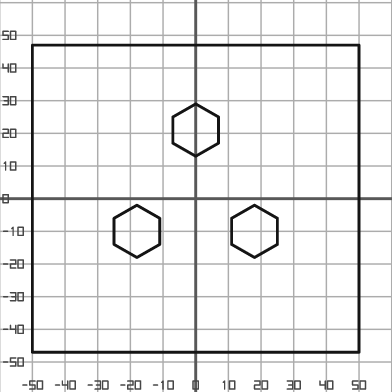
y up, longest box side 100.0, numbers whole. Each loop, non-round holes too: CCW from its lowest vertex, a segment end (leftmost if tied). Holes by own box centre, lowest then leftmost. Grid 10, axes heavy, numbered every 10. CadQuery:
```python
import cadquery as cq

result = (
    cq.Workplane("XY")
    .moveTo(-50.0, -47.0)
    .lineTo(50.0, -47.0)
    .lineTo(50.0, 47.0)
    .lineTo(-50.0, 47.0)
    .close()
    .moveTo(-18.0, -18.0)
    .lineTo(-11.0, -14.0)
    .lineTo(-11.0, -6.0)
    .lineTo(-18.0, -2.0)
    .lineTo(-25.0, -6.0)
    .lineTo(-25.0, -14.0)
    .close()
    .moveTo(18.0, -18.0)
    .lineTo(25.0, -14.0)
    .lineTo(25.0, -6.0)
    .lineTo(18.0, -2.0)
    .lineTo(11.0, -6.0)
    .lineTo(11.0, -14.0)
    .close()
    .moveTo(0.0, 13.0)
    .lineTo(7.0, 17.0)
    .lineTo(7.0, 25.0)
    .lineTo(0.0, 29.0)
    .lineTo(-7.0, 25.0)
    .lineTo(-7.0, 17.0)
    .close()
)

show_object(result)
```